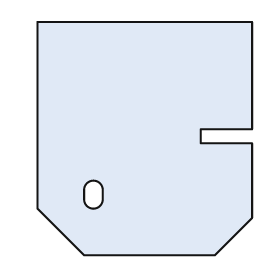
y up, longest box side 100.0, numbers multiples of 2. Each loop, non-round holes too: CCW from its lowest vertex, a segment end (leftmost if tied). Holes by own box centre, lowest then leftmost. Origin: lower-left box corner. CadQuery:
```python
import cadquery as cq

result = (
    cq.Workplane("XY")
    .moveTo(20.0, 0.0)
    .lineTo(76.0, 0.0)
    .lineTo(92.0, 16.0)
    .lineTo(92.0, 48.0)
    .lineTo(70.0, 48.0)
    .lineTo(70.0, 54.0)
    .lineTo(92.0, 54.0)
    .lineTo(92.0, 100.0)
    .lineTo(0.0, 100.0)
    .lineTo(0.0, 20.0)
    .close()
    .moveTo(20.0, 24.0)
    .threePointArc((24.0, 20.0), (28.0, 24.0))
    .lineTo(28.0, 28.0)
    .threePointArc((24.0, 32.0), (20.0, 28.0))
    .close()
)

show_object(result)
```